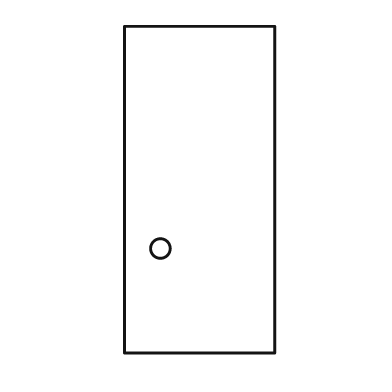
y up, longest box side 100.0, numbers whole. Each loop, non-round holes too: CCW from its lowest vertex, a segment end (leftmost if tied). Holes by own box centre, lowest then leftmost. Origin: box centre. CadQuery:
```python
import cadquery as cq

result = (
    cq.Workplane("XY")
    .moveTo(-23.0, -50.0)
    .lineTo(23.0, -50.0)
    .lineTo(23.0, 50.0)
    .lineTo(-23.0, 50.0)
    .close()
    .moveTo(-12.0, -18.0)
    .circle(3.0)
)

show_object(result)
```